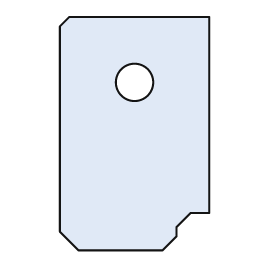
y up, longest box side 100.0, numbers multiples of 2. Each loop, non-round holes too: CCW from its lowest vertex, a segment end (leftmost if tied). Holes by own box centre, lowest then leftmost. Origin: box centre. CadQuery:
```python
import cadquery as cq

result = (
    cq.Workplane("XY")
    .moveTo(-24.0, -50.0)
    .lineTo(12.0, -50.0)
    .lineTo(18.0, -44.0)
    .lineTo(18.0, -40.0)
    .lineTo(24.0, -34.0)
    .lineTo(32.0, -34.0)
    .lineTo(32.0, 50.0)
    .lineTo(-28.0, 50.0)
    .lineTo(-32.0, 46.0)
    .lineTo(-32.0, -42.0)
    .close()
    .moveTo(0.0, 22.0)
    .circle(8.0)
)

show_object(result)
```